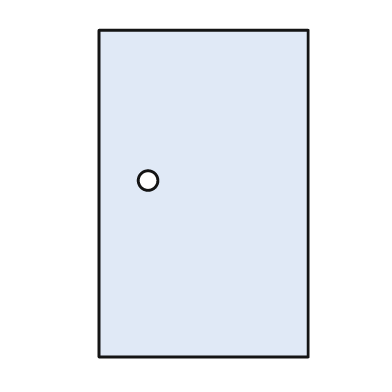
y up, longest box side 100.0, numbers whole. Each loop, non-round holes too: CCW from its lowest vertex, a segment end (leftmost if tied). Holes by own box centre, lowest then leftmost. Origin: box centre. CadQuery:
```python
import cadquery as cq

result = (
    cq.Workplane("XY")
    .moveTo(-32.0, -50.0)
    .lineTo(32.0, -50.0)
    .lineTo(32.0, 50.0)
    .lineTo(-32.0, 50.0)
    .close()
    .moveTo(-17.0, 4.0)
    .circle(3.0)
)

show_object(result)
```